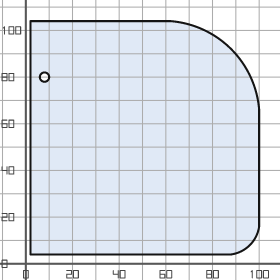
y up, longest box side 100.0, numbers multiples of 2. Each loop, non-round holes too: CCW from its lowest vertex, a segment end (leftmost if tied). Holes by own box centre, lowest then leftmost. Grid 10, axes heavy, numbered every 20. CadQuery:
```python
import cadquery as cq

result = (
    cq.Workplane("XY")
    .moveTo(2.0, 4.0)
    .lineTo(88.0, 4.0)
    .threePointArc((96.0, 8.0), (100.0, 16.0))
    .lineTo(100.0, 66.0)
    .threePointArc((88.0, 92.0), (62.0, 104.0))
    .lineTo(2.0, 104.0)
    .close()
    .moveTo(8.0, 80.0)
    .circle(2.0)
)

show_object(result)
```